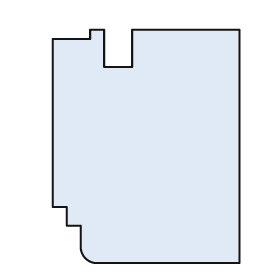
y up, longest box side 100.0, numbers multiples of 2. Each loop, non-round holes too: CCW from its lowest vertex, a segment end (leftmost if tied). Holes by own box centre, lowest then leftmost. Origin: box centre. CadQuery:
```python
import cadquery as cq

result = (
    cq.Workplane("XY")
    .moveTo(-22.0, -50.0)
    .lineTo(40.0, -50.0)
    .lineTo(40.0, 50.0)
    .lineTo(-6.0, 50.0)
    .lineTo(-6.0, 34.0)
    .lineTo(-18.0, 34.0)
    .lineTo(-18.0, 50.0)
    .lineTo(-24.0, 50.0)
    .lineTo(-24.0, 46.0)
    .lineTo(-40.0, 46.0)
    .lineTo(-40.0, -26.0)
    .lineTo(-34.0, -26.0)
    .lineTo(-34.0, -34.0)
    .lineTo(-28.0, -34.0)
    .lineTo(-28.0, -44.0)
    .threePointArc((-26.0, -48.0), (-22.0, -50.0))
    .close()
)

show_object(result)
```